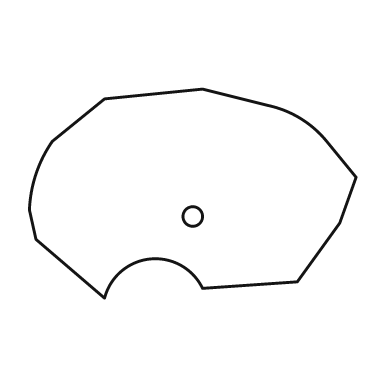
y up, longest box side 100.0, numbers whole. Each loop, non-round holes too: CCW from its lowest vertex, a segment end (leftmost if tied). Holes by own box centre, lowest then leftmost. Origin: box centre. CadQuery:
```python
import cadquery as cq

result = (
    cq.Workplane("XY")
    .moveTo(-27.0, -32.0)
    .threePointArc((-13.0, -20.0), (3.0, -29.0))
    .lineTo(32.0, -27.0)
    .lineTo(45.0, -9.0)
    .lineTo(50.0, 5.0)
    .lineTo(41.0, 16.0)
    .threePointArc((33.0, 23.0), (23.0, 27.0))
    .lineTo(3.0, 32.0)
    .lineTo(-27.0, 29.0)
    .lineTo(-43.0, 16.0)
    .threePointArc((-48.0, 6.0), (-50.0, -5.0))
    .lineTo(-48.0, -14.0)
    .close()
    .moveTo(0.0, -7.0)
    .circle(3.0)
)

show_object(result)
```